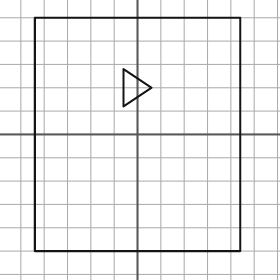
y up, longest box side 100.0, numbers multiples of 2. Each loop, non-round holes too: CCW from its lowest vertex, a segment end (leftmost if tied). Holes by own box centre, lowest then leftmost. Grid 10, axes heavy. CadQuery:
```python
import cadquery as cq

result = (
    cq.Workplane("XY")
    .moveTo(-44.0, -50.0)
    .lineTo(44.0, -50.0)
    .lineTo(44.0, 50.0)
    .lineTo(-44.0, 50.0)
    .close()
    .moveTo(-6.0, 12.0)
    .lineTo(6.0, 20.0)
    .lineTo(-6.0, 28.0)
    .close()
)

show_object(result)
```